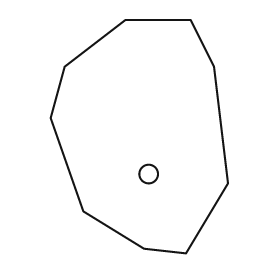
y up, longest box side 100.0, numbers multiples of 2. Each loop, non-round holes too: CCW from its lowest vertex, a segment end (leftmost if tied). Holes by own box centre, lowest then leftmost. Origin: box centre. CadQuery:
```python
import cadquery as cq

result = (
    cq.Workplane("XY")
    .moveTo(20.0, -50.0)
    .lineTo(38.0, -20.0)
    .lineTo(32.0, 30.0)
    .lineTo(22.0, 50.0)
    .lineTo(-6.0, 50.0)
    .lineTo(-32.0, 30.0)
    .lineTo(-38.0, 8.0)
    .lineTo(-24.0, -32.0)
    .lineTo(2.0, -48.0)
    .close()
    .moveTo(4.0, -16.0)
    .circle(4.0)
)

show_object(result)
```